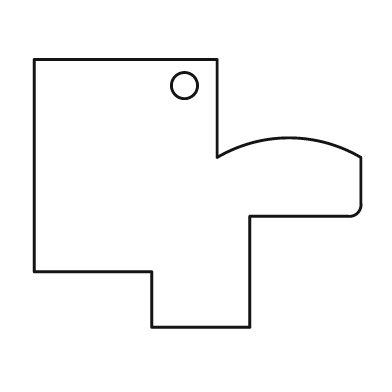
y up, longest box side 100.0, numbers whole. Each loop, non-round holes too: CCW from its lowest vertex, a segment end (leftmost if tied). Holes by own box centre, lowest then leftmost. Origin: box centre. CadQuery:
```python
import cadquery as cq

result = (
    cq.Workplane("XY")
    .moveTo(-14.0, -41.0)
    .lineTo(16.0, -41.0)
    .lineTo(16.0, -7.0)
    .lineTo(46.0, -7.0)
    .threePointArc((49.0, -6.0), (50.0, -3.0))
    .lineTo(50.0, 11.0)
    .threePointArc((28.0, 17.0), (6.0, 11.0))
    .lineTo(6.0, 41.0)
    .lineTo(-50.0, 41.0)
    .lineTo(-50.0, -24.0)
    .lineTo(-14.0, -24.0)
    .close()
    .moveTo(-4.0, 33.0)
    .circle(4.0)
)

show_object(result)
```